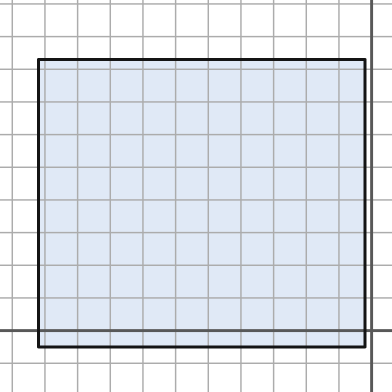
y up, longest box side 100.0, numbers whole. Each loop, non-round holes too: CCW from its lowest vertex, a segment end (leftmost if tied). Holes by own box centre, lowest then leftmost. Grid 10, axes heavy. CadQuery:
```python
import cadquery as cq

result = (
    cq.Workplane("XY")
    .moveTo(-102.0, -5.0)
    .lineTo(-2.0, -5.0)
    .lineTo(-2.0, 83.0)
    .lineTo(-102.0, 83.0)
    .close()
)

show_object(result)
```